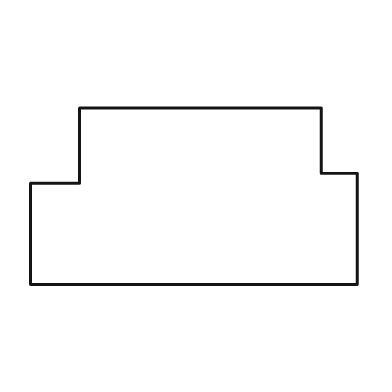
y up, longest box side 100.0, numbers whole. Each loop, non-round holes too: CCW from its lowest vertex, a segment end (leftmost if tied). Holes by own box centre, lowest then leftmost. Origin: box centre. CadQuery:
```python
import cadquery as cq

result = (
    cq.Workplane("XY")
    .moveTo(-50.0, -27.0)
    .lineTo(50.0, -27.0)
    .lineTo(50.0, 7.0)
    .lineTo(39.0, 7.0)
    .lineTo(39.0, 27.0)
    .lineTo(-35.0, 27.0)
    .lineTo(-35.0, 4.0)
    .lineTo(-50.0, 4.0)
    .close()
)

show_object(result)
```